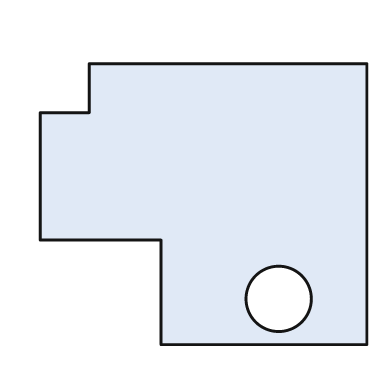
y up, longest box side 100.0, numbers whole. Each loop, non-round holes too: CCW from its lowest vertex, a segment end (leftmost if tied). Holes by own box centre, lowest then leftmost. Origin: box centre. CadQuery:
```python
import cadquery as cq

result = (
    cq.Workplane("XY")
    .moveTo(-13.0, -43.0)
    .lineTo(50.0, -43.0)
    .lineTo(50.0, 43.0)
    .lineTo(-35.0, 43.0)
    .lineTo(-35.0, 28.0)
    .lineTo(-50.0, 28.0)
    .lineTo(-50.0, -11.0)
    .lineTo(-13.0, -11.0)
    .close()
    .moveTo(23.0, -29.0)
    .circle(10.0)
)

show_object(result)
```